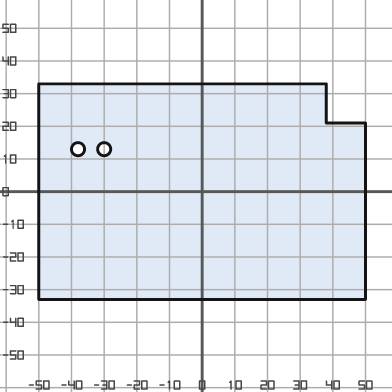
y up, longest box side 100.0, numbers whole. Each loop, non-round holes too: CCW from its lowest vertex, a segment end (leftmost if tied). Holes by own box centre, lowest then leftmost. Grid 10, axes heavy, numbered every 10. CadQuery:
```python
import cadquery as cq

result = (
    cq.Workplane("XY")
    .moveTo(-50.0, -33.0)
    .lineTo(50.0, -33.0)
    .lineTo(50.0, 21.0)
    .lineTo(38.0, 21.0)
    .lineTo(38.0, 33.0)
    .lineTo(-50.0, 33.0)
    .close()
    .moveTo(-38.0, 13.0)
    .circle(2.0)
    .moveTo(-30.0, 13.0)
    .circle(2.0)
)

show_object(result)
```